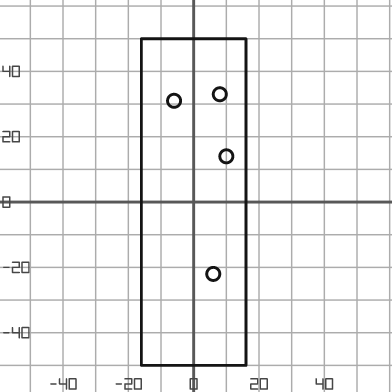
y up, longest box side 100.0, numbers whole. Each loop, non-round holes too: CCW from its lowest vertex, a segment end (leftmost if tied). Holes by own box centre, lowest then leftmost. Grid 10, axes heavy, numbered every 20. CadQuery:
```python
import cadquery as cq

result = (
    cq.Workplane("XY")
    .moveTo(-16.0, -50.0)
    .lineTo(16.0, -50.0)
    .lineTo(16.0, 50.0)
    .lineTo(-16.0, 50.0)
    .close()
    .moveTo(6.0, -22.0)
    .circle(2.0)
    .moveTo(10.0, 14.0)
    .circle(2.0)
    .moveTo(-6.0, 31.0)
    .circle(2.0)
    .moveTo(8.0, 33.0)
    .circle(2.0)
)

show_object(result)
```